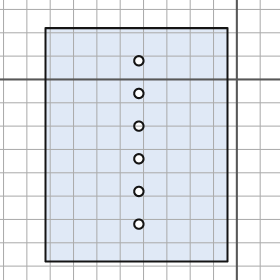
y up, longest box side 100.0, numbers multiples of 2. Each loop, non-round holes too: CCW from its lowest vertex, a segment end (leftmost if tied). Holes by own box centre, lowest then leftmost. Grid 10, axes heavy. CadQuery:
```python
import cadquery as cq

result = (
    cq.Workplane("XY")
    .moveTo(-82.0, -78.0)
    .lineTo(-4.0, -78.0)
    .lineTo(-4.0, 22.0)
    .lineTo(-82.0, 22.0)
    .close()
    .moveTo(-42.0, -62.0)
    .circle(2.0)
    .moveTo(-42.0, -48.0)
    .circle(2.0)
    .moveTo(-42.0, -34.0)
    .circle(2.0)
    .moveTo(-42.0, -20.0)
    .circle(2.0)
    .moveTo(-42.0, -6.0)
    .circle(2.0)
    .moveTo(-42.0, 8.0)
    .circle(2.0)
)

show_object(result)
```